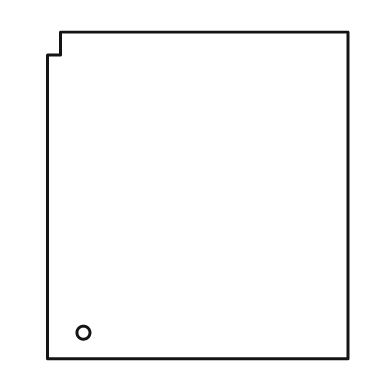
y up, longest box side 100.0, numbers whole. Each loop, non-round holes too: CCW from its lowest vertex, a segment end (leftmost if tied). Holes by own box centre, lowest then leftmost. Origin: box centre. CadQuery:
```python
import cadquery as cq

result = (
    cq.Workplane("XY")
    .moveTo(-46.0, -50.0)
    .lineTo(46.0, -50.0)
    .lineTo(46.0, 50.0)
    .lineTo(-42.0, 50.0)
    .lineTo(-42.0, 43.0)
    .lineTo(-46.0, 43.0)
    .close()
    .moveTo(-35.0, -42.0)
    .circle(2.0)
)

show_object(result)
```